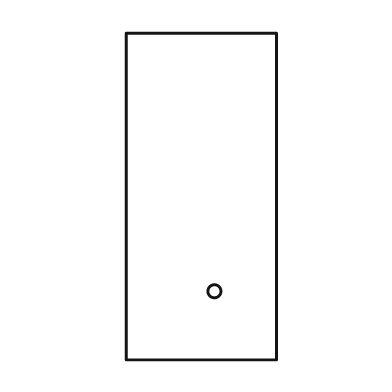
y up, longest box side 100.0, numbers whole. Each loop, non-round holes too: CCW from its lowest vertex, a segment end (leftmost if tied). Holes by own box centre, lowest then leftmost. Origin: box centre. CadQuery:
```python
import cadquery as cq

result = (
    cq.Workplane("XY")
    .moveTo(-23.0, -50.0)
    .lineTo(23.0, -50.0)
    .lineTo(23.0, 50.0)
    .lineTo(-23.0, 50.0)
    .close()
    .moveTo(4.0, -29.0)
    .circle(2.0)
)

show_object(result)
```